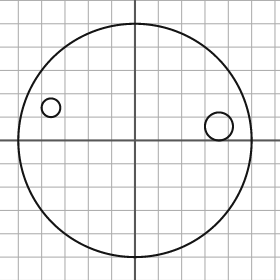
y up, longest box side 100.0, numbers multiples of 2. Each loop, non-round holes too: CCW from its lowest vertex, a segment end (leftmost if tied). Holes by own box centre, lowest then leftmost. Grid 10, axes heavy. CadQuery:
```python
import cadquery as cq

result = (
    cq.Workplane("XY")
    .moveTo(0.0, 0.0)
    .circle(50.0)
    .moveTo(36.0, 6.0)
    .circle(6.0)
    .moveTo(-36.0, 14.0)
    .circle(4.0)
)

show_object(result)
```